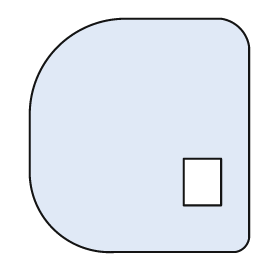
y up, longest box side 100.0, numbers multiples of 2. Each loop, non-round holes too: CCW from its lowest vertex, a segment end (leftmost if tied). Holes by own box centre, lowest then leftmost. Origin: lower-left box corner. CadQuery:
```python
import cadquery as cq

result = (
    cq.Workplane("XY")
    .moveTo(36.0, 0.0)
    .lineTo(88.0, 0.0)
    .threePointArc((92.0, 2.0), (94.0, 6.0))
    .lineTo(94.0, 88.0)
    .threePointArc((90.0, 96.0), (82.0, 100.0))
    .lineTo(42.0, 100.0)
    .threePointArc((12.0, 88.0), (0.0, 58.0))
    .lineTo(0.0, 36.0)
    .threePointArc((10.0, 10.0), (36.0, 0.0))
    .close()
    .moveTo(66.0, 20.0)
    .lineTo(82.0, 20.0)
    .lineTo(82.0, 40.0)
    .lineTo(66.0, 40.0)
    .close()
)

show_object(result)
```